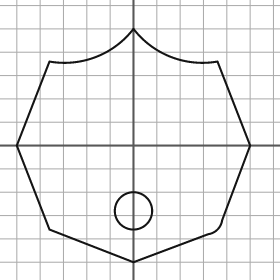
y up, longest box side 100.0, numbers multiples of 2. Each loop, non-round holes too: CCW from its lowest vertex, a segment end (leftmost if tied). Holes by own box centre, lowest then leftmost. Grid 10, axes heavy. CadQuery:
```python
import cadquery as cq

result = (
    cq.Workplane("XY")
    .moveTo(0.0, -50.0)
    .lineTo(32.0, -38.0)
    .threePointArc((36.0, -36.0), (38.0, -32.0))
    .lineTo(50.0, 0.0)
    .lineTo(36.0, 36.0)
    .threePointArc((16.0, 38.0), (0.0, 50.0))
    .threePointArc((-16.0, 38.0), (-36.0, 36.0))
    .lineTo(-50.0, 0.0)
    .lineTo(-36.0, -36.0)
    .close()
    .moveTo(0.0, -28.0)
    .circle(8.0)
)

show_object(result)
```